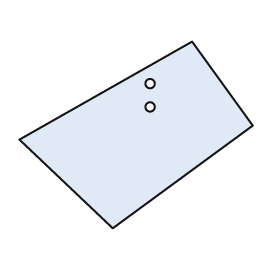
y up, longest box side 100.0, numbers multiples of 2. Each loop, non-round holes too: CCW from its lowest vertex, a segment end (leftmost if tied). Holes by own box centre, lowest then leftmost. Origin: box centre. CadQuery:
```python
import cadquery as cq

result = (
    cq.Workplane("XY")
    .moveTo(-10.0, -40.0)
    .lineTo(50.0, 4.0)
    .lineTo(24.0, 40.0)
    .lineTo(-50.0, -2.0)
    .close()
    .moveTo(6.0, 12.0)
    .circle(2.0)
    .moveTo(6.0, 22.0)
    .circle(2.0)
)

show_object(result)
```